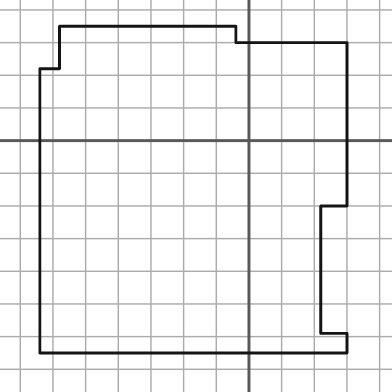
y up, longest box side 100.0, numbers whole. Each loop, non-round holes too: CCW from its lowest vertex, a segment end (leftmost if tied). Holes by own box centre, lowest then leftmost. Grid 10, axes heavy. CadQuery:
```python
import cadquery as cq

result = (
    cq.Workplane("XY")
    .moveTo(-64.0, -65.0)
    .lineTo(30.0, -65.0)
    .lineTo(30.0, -59.0)
    .lineTo(22.0, -59.0)
    .lineTo(22.0, -20.0)
    .lineTo(30.0, -20.0)
    .lineTo(30.0, 30.0)
    .lineTo(-4.0, 30.0)
    .lineTo(-4.0, 35.0)
    .lineTo(-58.0, 35.0)
    .lineTo(-58.0, 22.0)
    .lineTo(-64.0, 22.0)
    .close()
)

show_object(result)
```